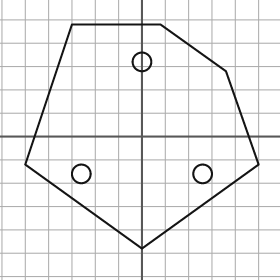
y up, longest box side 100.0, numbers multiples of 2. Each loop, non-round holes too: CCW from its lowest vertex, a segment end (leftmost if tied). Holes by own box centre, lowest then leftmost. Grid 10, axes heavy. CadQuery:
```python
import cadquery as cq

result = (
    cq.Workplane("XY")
    .moveTo(0.0, -48.0)
    .lineTo(50.0, -12.0)
    .lineTo(36.0, 28.0)
    .lineTo(8.0, 48.0)
    .lineTo(-30.0, 48.0)
    .lineTo(-50.0, -12.0)
    .close()
    .moveTo(-26.0, -16.0)
    .circle(4.0)
    .moveTo(26.0, -16.0)
    .circle(4.0)
    .moveTo(0.0, 32.0)
    .circle(4.0)
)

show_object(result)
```